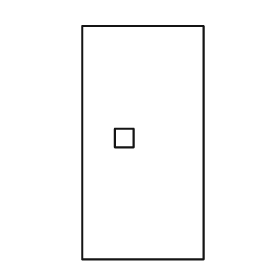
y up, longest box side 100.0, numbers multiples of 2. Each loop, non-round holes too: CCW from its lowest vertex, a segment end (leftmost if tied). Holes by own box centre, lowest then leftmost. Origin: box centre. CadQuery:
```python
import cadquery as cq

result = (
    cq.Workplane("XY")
    .moveTo(-26.0, -50.0)
    .lineTo(26.0, -50.0)
    .lineTo(26.0, 50.0)
    .lineTo(-26.0, 50.0)
    .close()
    .moveTo(-12.0, -2.0)
    .lineTo(-4.0, -2.0)
    .lineTo(-4.0, 6.0)
    .lineTo(-12.0, 6.0)
    .close()
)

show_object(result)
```